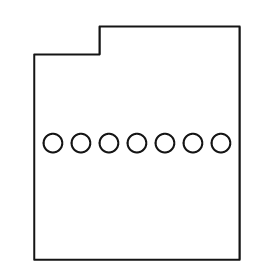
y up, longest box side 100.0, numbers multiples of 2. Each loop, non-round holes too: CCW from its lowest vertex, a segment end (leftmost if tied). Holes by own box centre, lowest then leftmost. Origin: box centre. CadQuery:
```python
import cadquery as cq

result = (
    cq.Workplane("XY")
    .moveTo(-44.0, -50.0)
    .lineTo(44.0, -50.0)
    .lineTo(44.0, 50.0)
    .lineTo(-16.0, 50.0)
    .lineTo(-16.0, 38.0)
    .lineTo(-44.0, 38.0)
    .close()
    .moveTo(-36.0, 0.0)
    .circle(4.0)
    .moveTo(-24.0, 0.0)
    .circle(4.0)
    .moveTo(-12.0, 0.0)
    .circle(4.0)
    .moveTo(0.0, 0.0)
    .circle(4.0)
    .moveTo(12.0, 0.0)
    .circle(4.0)
    .moveTo(24.0, 0.0)
    .circle(4.0)
    .moveTo(36.0, 0.0)
    .circle(4.0)
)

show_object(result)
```